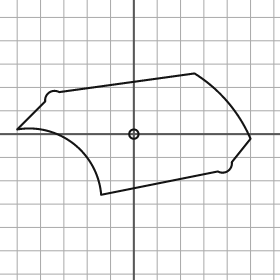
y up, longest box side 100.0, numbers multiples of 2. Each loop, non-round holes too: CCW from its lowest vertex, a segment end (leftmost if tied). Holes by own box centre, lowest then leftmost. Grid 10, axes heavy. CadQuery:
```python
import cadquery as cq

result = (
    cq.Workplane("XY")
    .moveTo(-14.0, -26.0)
    .lineTo(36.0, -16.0)
    .threePointArc((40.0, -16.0), (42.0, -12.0))
    .lineTo(50.0, -2.0)
    .threePointArc((40.0, 14.0), (26.0, 26.0))
    .lineTo(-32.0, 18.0)
    .threePointArc((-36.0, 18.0), (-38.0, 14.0))
    .lineTo(-50.0, 2.0)
    .threePointArc((-26.0, -4.0), (-14.0, -26.0))
    .close()
    .moveTo(0.0, 0.0)
    .circle(2.0)
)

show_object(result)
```